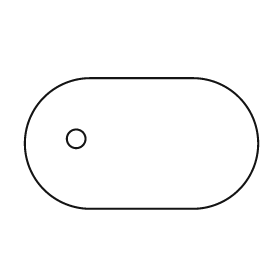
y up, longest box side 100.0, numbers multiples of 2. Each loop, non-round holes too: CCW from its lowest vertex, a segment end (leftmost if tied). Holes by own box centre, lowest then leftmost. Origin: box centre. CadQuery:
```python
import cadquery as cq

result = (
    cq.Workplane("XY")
    .moveTo(-22.0, -28.0)
    .lineTo(22.0, -28.0)
    .threePointArc((50.0, 0.0), (22.0, 28.0))
    .lineTo(-22.0, 28.0)
    .threePointArc((-50.0, 0.0), (-22.0, -28.0))
    .close()
    .moveTo(-28.0, 2.0)
    .circle(4.0)
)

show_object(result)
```